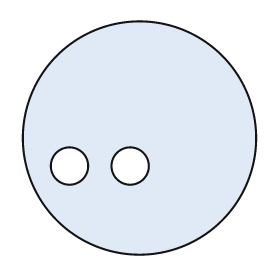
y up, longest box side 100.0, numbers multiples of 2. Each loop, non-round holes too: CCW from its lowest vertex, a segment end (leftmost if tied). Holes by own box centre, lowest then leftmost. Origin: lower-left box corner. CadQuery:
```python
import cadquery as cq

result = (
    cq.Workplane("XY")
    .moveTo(50.0, 50.0)
    .circle(50.0)
    .moveTo(20.0, 38.0)
    .circle(8.0)
    .moveTo(46.0, 38.0)
    .circle(8.0)
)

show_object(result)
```